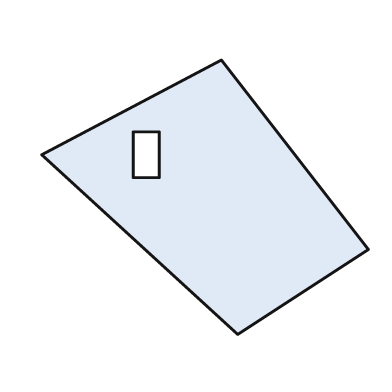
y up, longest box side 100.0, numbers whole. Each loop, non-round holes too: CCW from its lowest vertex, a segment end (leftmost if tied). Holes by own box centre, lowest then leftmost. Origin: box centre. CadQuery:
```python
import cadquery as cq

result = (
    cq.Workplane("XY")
    .moveTo(10.0, -42.0)
    .lineTo(50.0, -16.0)
    .lineTo(5.0, 42.0)
    .lineTo(-50.0, 13.0)
    .close()
    .moveTo(-22.0, 6.0)
    .lineTo(-14.0, 6.0)
    .lineTo(-14.0, 20.0)
    .lineTo(-22.0, 20.0)
    .close()
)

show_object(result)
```